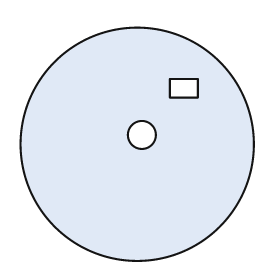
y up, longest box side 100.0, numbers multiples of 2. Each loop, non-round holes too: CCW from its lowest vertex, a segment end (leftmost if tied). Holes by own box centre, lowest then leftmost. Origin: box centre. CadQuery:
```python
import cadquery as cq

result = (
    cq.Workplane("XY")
    .moveTo(0.0, 0.0)
    .circle(50.0)
    .moveTo(2.0, 4.0)
    .circle(6.0)
    .moveTo(14.0, 20.0)
    .lineTo(26.0, 20.0)
    .lineTo(26.0, 28.0)
    .lineTo(14.0, 28.0)
    .close()
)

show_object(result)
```